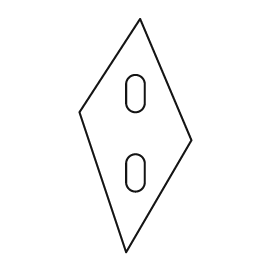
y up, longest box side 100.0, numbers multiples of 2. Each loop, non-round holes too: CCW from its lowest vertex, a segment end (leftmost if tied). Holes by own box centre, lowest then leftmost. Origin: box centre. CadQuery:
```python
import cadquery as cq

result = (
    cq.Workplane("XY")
    .moveTo(-4.0, -50.0)
    .lineTo(24.0, -2.0)
    .lineTo(2.0, 50.0)
    .lineTo(-24.0, 10.0)
    .close()
    .moveTo(-4.0, -20.0)
    .threePointArc((0.0, -24.0), (4.0, -20.0))
    .lineTo(4.0, -12.0)
    .threePointArc((0.0, -8.0), (-4.0, -12.0))
    .close()
    .moveTo(-4.0, 14.0)
    .threePointArc((0.0, 10.0), (4.0, 14.0))
    .lineTo(4.0, 22.0)
    .threePointArc((0.0, 26.0), (-4.0, 22.0))
    .close()
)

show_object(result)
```